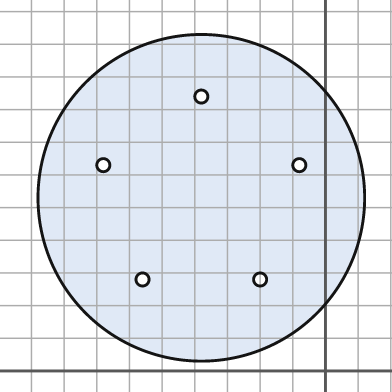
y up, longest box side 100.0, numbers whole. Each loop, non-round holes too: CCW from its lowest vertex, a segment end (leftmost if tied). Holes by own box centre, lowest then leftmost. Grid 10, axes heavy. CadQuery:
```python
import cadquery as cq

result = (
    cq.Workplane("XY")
    .moveTo(-38.0, 53.0)
    .circle(50.0)
    .moveTo(-56.0, 28.0)
    .circle(2.0)
    .moveTo(-20.0, 28.0)
    .circle(2.0)
    .moveTo(-68.0, 63.0)
    .circle(2.0)
    .moveTo(-8.0, 63.0)
    .circle(2.0)
    .moveTo(-38.0, 84.0)
    .circle(2.0)
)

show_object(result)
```